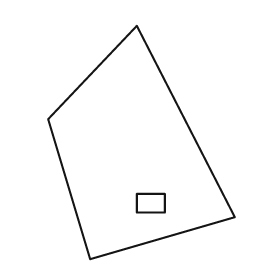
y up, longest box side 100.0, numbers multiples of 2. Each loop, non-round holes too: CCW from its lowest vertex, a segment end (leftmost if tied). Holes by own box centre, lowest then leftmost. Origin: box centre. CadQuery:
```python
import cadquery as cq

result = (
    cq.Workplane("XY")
    .moveTo(-22.0, -50.0)
    .lineTo(40.0, -32.0)
    .lineTo(-2.0, 50.0)
    .lineTo(-40.0, 10.0)
    .close()
    .moveTo(-2.0, -30.0)
    .lineTo(10.0, -30.0)
    .lineTo(10.0, -22.0)
    .lineTo(-2.0, -22.0)
    .close()
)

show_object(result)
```